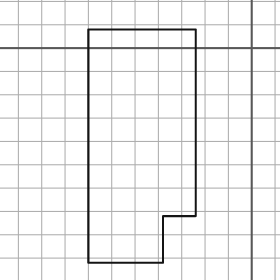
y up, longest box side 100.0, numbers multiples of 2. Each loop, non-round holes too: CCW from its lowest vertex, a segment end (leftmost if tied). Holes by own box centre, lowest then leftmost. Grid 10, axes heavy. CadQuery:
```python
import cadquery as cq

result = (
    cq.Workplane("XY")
    .moveTo(-70.0, -92.0)
    .lineTo(-38.0, -92.0)
    .lineTo(-38.0, -72.0)
    .lineTo(-24.0, -72.0)
    .lineTo(-24.0, 8.0)
    .lineTo(-70.0, 8.0)
    .close()
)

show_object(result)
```